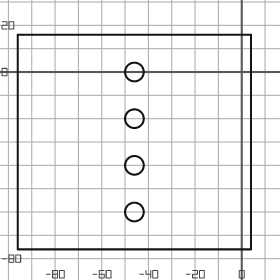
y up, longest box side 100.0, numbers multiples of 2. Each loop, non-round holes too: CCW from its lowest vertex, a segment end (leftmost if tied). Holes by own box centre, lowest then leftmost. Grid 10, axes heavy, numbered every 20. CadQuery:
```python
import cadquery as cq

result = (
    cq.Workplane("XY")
    .moveTo(-96.0, -76.0)
    .lineTo(4.0, -76.0)
    .lineTo(4.0, 16.0)
    .lineTo(-96.0, 16.0)
    .close()
    .moveTo(-46.0, -60.0)
    .circle(4.0)
    .moveTo(-46.0, -40.0)
    .circle(4.0)
    .moveTo(-46.0, -20.0)
    .circle(4.0)
    .moveTo(-46.0, 0.0)
    .circle(4.0)
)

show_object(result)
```